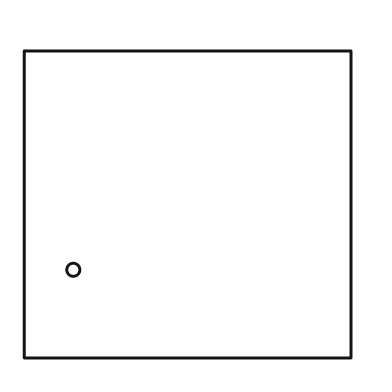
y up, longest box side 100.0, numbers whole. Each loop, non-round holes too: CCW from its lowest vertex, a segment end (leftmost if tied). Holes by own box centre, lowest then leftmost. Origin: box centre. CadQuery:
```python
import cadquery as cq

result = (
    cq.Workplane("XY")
    .moveTo(-50.0, -47.0)
    .lineTo(50.0, -47.0)
    .lineTo(50.0, 47.0)
    .lineTo(-50.0, 47.0)
    .close()
    .moveTo(-35.0, -20.0)
    .circle(2.0)
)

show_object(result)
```